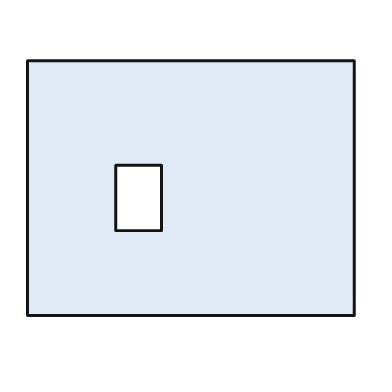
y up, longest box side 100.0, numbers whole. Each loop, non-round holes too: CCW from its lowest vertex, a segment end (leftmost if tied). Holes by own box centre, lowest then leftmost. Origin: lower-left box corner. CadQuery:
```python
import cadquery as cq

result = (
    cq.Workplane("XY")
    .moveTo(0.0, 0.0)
    .lineTo(100.0, 0.0)
    .lineTo(100.0, 78.0)
    .lineTo(0.0, 78.0)
    .close()
    .moveTo(27.0, 26.0)
    .lineTo(41.0, 26.0)
    .lineTo(41.0, 46.0)
    .lineTo(27.0, 46.0)
    .close()
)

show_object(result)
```